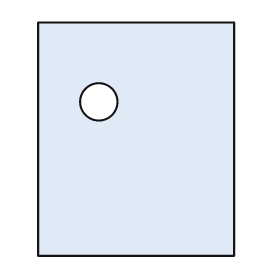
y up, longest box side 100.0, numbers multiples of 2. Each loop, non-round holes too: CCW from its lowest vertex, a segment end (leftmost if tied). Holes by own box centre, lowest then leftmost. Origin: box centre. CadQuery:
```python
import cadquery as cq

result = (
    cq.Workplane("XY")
    .moveTo(-42.0, -50.0)
    .lineTo(42.0, -50.0)
    .lineTo(42.0, 50.0)
    .lineTo(-42.0, 50.0)
    .close()
    .moveTo(-16.0, 16.0)
    .circle(8.0)
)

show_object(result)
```